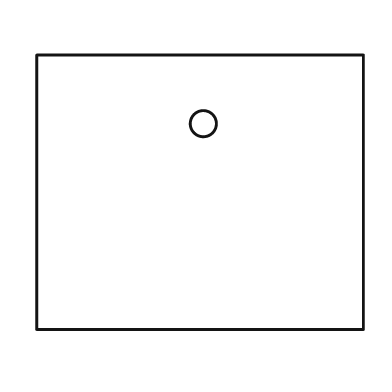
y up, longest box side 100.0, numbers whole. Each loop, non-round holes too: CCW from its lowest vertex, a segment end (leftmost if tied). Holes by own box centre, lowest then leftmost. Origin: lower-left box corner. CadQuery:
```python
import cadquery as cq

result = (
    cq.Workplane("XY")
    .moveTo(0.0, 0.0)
    .lineTo(100.0, 0.0)
    .lineTo(100.0, 84.0)
    .lineTo(0.0, 84.0)
    .close()
    .moveTo(51.0, 63.0)
    .circle(4.0)
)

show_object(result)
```